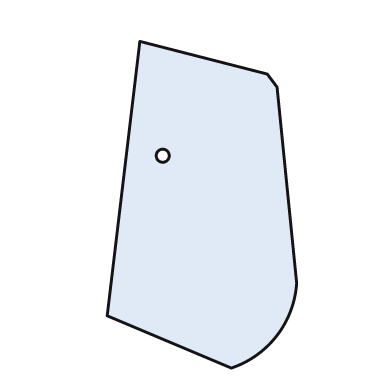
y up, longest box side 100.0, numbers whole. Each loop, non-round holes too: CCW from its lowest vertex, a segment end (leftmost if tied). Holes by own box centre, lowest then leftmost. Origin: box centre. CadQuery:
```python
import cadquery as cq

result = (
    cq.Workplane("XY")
    .moveTo(9.0, -50.0)
    .threePointArc((23.0, -40.0), (29.0, -24.0))
    .lineTo(23.0, 36.0)
    .lineTo(20.0, 40.0)
    .lineTo(-19.0, 50.0)
    .lineTo(-29.0, -34.0)
    .close()
    .moveTo(-12.0, 15.0)
    .circle(2.0)
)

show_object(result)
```